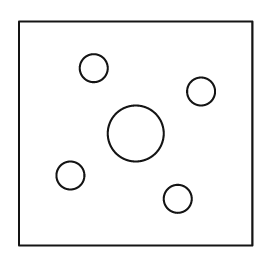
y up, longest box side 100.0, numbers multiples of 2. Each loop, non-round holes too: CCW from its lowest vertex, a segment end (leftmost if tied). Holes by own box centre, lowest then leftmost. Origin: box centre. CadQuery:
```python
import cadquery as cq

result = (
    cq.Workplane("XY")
    .moveTo(-50.0, -48.0)
    .lineTo(50.0, -48.0)
    .lineTo(50.0, 48.0)
    .lineTo(-50.0, 48.0)
    .close()
    .moveTo(18.0, -28.0)
    .circle(6.0)
    .moveTo(-28.0, -18.0)
    .circle(6.0)
    .moveTo(0.0, 0.0)
    .circle(12.0)
    .moveTo(28.0, 18.0)
    .circle(6.0)
    .moveTo(-18.0, 28.0)
    .circle(6.0)
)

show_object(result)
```